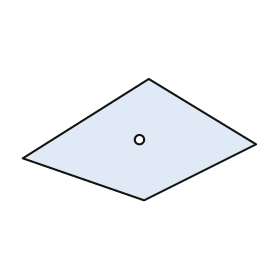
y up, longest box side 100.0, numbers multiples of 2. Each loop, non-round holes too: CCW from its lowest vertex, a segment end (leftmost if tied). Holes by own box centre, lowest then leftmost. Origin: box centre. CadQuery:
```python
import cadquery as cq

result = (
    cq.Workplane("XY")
    .moveTo(2.0, -26.0)
    .lineTo(50.0, -2.0)
    .lineTo(4.0, 26.0)
    .lineTo(-50.0, -8.0)
    .close()
    .moveTo(0.0, 0.0)
    .circle(2.0)
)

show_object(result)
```